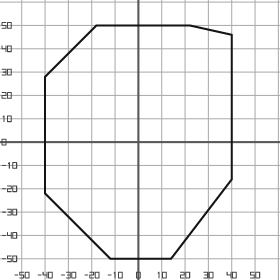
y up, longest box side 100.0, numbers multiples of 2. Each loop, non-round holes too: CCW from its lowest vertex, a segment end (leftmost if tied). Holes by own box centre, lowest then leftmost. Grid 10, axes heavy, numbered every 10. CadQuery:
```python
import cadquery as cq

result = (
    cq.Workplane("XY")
    .moveTo(-12.0, -50.0)
    .lineTo(14.0, -50.0)
    .lineTo(40.0, -16.0)
    .lineTo(40.0, 46.0)
    .lineTo(22.0, 50.0)
    .lineTo(-18.0, 50.0)
    .lineTo(-40.0, 28.0)
    .lineTo(-40.0, -22.0)
    .close()
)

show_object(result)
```